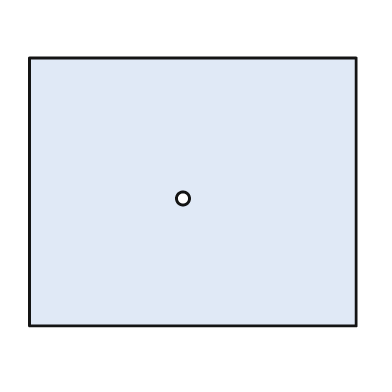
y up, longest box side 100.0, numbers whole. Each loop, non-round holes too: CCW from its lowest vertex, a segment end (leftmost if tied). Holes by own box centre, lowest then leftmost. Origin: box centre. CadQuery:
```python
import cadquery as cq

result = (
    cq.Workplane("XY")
    .moveTo(-50.0, -41.0)
    .lineTo(50.0, -41.0)
    .lineTo(50.0, 41.0)
    .lineTo(-50.0, 41.0)
    .close()
    .moveTo(-3.0, -2.0)
    .circle(2.0)
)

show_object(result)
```